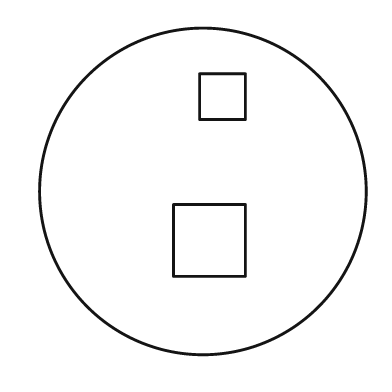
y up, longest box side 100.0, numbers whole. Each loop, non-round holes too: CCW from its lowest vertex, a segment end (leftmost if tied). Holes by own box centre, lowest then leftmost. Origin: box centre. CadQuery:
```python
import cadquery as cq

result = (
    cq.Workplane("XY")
    .moveTo(0.0, 0.0)
    .circle(50.0)
    .moveTo(-9.0, -26.0)
    .lineTo(13.0, -26.0)
    .lineTo(13.0, -4.0)
    .lineTo(-9.0, -4.0)
    .close()
    .moveTo(-1.0, 22.0)
    .lineTo(13.0, 22.0)
    .lineTo(13.0, 36.0)
    .lineTo(-1.0, 36.0)
    .close()
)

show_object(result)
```